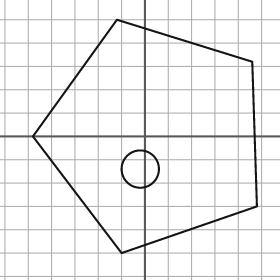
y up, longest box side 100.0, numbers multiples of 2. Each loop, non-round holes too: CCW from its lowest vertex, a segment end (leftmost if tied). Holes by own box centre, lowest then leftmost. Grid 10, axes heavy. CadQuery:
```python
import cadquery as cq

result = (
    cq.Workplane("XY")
    .moveTo(-10.0, -50.0)
    .lineTo(48.0, -30.0)
    .lineTo(46.0, 32.0)
    .lineTo(-12.0, 50.0)
    .lineTo(-48.0, 0.0)
    .close()
    .moveTo(-2.0, -14.0)
    .circle(8.0)
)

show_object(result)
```